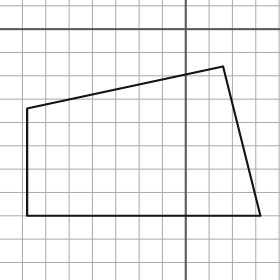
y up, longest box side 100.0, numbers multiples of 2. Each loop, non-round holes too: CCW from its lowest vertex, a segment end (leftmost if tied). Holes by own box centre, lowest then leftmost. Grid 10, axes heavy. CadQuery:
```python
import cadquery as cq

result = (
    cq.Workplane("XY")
    .moveTo(-68.0, -80.0)
    .lineTo(32.0, -80.0)
    .lineTo(16.0, -16.0)
    .lineTo(-68.0, -34.0)
    .close()
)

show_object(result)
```